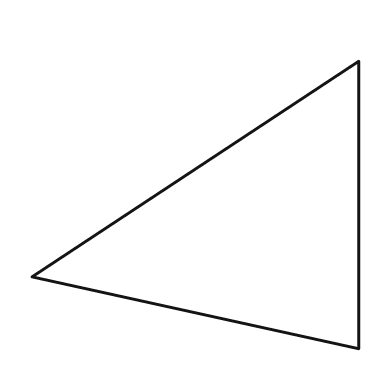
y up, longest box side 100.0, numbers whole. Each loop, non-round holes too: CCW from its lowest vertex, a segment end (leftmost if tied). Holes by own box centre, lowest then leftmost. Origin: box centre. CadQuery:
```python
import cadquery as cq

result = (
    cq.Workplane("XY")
    .moveTo(50.0, -44.0)
    .lineTo(50.0, 44.0)
    .lineTo(-50.0, -22.0)
    .close()
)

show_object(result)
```